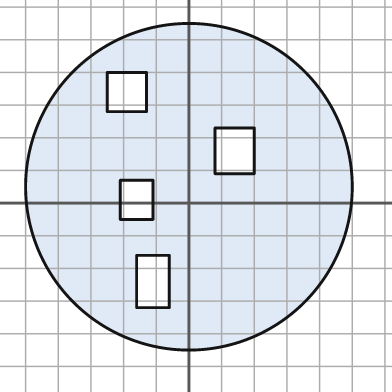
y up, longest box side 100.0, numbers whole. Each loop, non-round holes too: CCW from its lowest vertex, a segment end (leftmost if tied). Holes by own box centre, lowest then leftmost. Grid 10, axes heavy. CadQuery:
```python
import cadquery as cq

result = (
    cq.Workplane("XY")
    .moveTo(0.0, 5.0)
    .circle(50.0)
    .moveTo(-16.0, -32.0)
    .lineTo(-6.0, -32.0)
    .lineTo(-6.0, -16.0)
    .lineTo(-16.0, -16.0)
    .close()
    .moveTo(-21.0, -5.0)
    .lineTo(-11.0, -5.0)
    .lineTo(-11.0, 7.0)
    .lineTo(-21.0, 7.0)
    .close()
    .moveTo(8.0, 9.0)
    .lineTo(20.0, 9.0)
    .lineTo(20.0, 23.0)
    .lineTo(8.0, 23.0)
    .close()
    .moveTo(-25.0, 28.0)
    .lineTo(-13.0, 28.0)
    .lineTo(-13.0, 40.0)
    .lineTo(-25.0, 40.0)
    .close()
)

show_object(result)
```